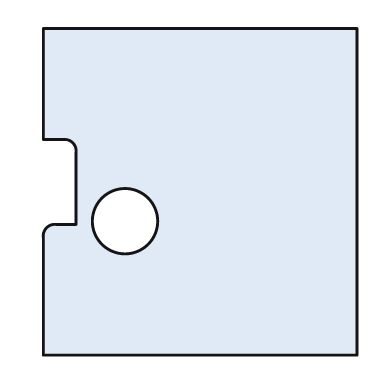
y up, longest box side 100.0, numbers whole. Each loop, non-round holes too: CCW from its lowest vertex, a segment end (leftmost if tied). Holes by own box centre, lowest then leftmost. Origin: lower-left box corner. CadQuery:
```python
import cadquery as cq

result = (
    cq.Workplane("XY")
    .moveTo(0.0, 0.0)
    .lineTo(96.0, 0.0)
    .lineTo(96.0, 100.0)
    .lineTo(0.0, 100.0)
    .lineTo(0.0, 66.0)
    .lineTo(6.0, 66.0)
    .threePointArc((9.0, 65.0), (10.0, 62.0))
    .lineTo(10.0, 40.0)
    .lineTo(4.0, 40.0)
    .threePointArc((1.0, 39.0), (0.0, 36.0))
    .close()
    .moveTo(25.0, 41.0)
    .circle(10.0)
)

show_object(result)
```